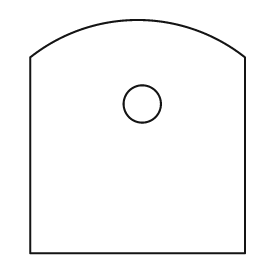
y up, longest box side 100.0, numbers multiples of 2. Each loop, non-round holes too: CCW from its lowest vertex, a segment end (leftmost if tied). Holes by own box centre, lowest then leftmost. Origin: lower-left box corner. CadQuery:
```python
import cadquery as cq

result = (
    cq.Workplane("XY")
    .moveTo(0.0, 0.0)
    .lineTo(92.0, 0.0)
    .lineTo(92.0, 84.0)
    .threePointArc((46.0, 100.0), (0.0, 84.0))
    .close()
    .moveTo(48.0, 64.0)
    .circle(8.0)
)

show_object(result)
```